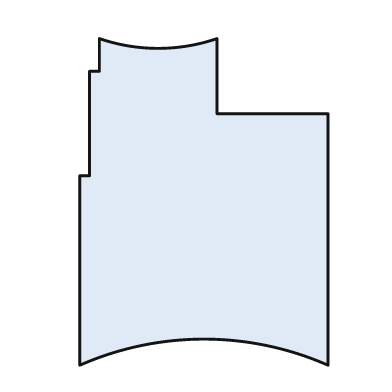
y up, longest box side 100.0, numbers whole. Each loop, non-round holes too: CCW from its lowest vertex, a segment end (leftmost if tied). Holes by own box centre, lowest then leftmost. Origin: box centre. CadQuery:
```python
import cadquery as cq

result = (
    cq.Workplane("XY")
    .moveTo(-38.0, -50.0)
    .threePointArc((0.0, -42.0), (38.0, -50.0))
    .lineTo(38.0, 27.0)
    .lineTo(4.0, 27.0)
    .lineTo(4.0, 50.0)
    .threePointArc((-14.0, 47.0), (-32.0, 50.0))
    .lineTo(-32.0, 40.0)
    .lineTo(-35.0, 40.0)
    .lineTo(-35.0, 8.0)
    .lineTo(-38.0, 8.0)
    .close()
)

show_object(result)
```